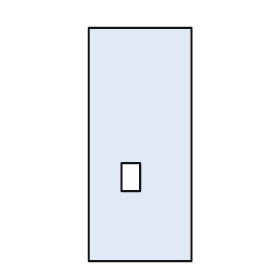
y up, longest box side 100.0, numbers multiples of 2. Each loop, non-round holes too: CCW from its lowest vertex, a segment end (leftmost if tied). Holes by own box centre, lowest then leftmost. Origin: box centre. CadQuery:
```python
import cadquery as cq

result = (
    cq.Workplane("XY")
    .moveTo(-22.0, -50.0)
    .lineTo(22.0, -50.0)
    .lineTo(22.0, 50.0)
    .lineTo(-22.0, 50.0)
    .close()
    .moveTo(-8.0, -20.0)
    .lineTo(0.0, -20.0)
    .lineTo(0.0, -8.0)
    .lineTo(-8.0, -8.0)
    .close()
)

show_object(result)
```